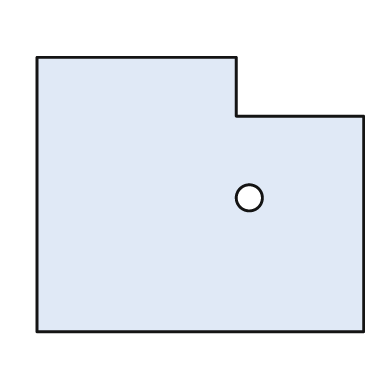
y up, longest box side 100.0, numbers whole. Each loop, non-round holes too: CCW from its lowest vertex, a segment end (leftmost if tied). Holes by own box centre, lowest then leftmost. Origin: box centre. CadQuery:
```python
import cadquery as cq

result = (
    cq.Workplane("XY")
    .moveTo(-50.0, -42.0)
    .lineTo(50.0, -42.0)
    .lineTo(50.0, 24.0)
    .lineTo(11.0, 24.0)
    .lineTo(11.0, 42.0)
    .lineTo(-50.0, 42.0)
    .close()
    .moveTo(15.0, -1.0)
    .circle(4.0)
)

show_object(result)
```